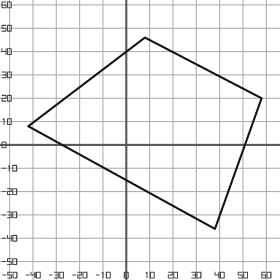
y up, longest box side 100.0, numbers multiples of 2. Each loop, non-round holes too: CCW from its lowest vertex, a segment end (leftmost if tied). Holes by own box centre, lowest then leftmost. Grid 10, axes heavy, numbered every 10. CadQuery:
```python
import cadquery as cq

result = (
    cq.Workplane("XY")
    .moveTo(38.0, -36.0)
    .lineTo(58.0, 20.0)
    .lineTo(8.0, 46.0)
    .lineTo(-42.0, 8.0)
    .close()
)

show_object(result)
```